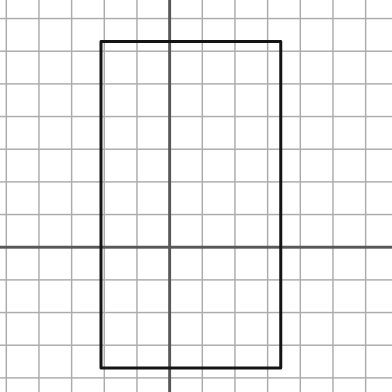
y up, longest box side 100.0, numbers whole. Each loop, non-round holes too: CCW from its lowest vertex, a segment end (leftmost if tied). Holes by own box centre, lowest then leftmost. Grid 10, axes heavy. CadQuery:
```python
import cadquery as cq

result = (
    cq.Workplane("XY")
    .moveTo(-21.0, -37.0)
    .lineTo(34.0, -37.0)
    .lineTo(34.0, 63.0)
    .lineTo(-21.0, 63.0)
    .close()
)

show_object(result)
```